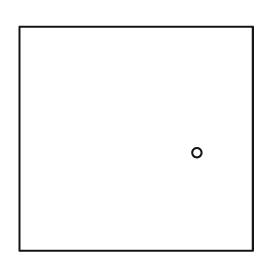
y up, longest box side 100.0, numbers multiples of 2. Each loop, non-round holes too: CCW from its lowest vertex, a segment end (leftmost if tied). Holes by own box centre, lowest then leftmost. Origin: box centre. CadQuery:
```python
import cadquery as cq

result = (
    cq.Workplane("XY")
    .moveTo(-50.0, -48.0)
    .lineTo(50.0, -48.0)
    .lineTo(50.0, 48.0)
    .lineTo(-50.0, 48.0)
    .close()
    .moveTo(26.0, -6.0)
    .circle(2.0)
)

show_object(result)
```